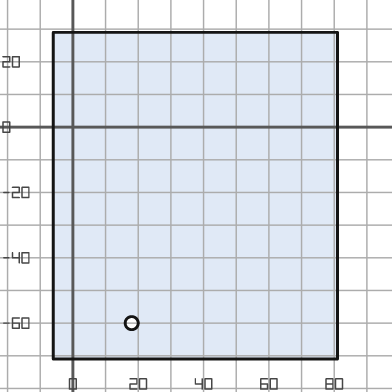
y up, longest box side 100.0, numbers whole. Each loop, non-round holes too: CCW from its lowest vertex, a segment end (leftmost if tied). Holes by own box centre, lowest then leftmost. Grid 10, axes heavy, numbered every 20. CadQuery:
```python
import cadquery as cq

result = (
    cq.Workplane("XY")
    .moveTo(-6.0, -71.0)
    .lineTo(81.0, -71.0)
    .lineTo(81.0, 29.0)
    .lineTo(-6.0, 29.0)
    .close()
    .moveTo(18.0, -60.0)
    .circle(2.0)
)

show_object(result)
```